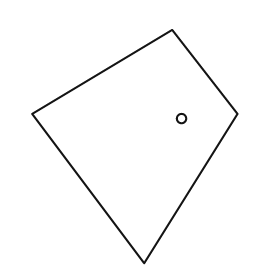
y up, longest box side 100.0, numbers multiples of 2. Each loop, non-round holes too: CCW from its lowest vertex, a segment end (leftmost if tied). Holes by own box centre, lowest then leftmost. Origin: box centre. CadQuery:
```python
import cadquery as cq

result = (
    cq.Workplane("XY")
    .moveTo(4.0, -50.0)
    .lineTo(44.0, 14.0)
    .lineTo(16.0, 50.0)
    .lineTo(-44.0, 14.0)
    .close()
    .moveTo(20.0, 12.0)
    .circle(2.0)
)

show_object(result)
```